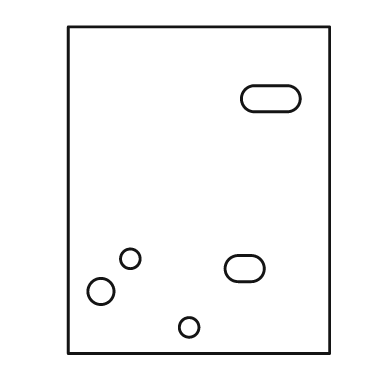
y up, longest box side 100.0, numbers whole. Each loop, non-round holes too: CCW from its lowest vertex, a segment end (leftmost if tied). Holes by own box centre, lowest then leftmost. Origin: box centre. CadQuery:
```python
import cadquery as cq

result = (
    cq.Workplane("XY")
    .moveTo(-40.0, -50.0)
    .lineTo(40.0, -50.0)
    .lineTo(40.0, 50.0)
    .lineTo(-40.0, 50.0)
    .close()
    .moveTo(-3.0, -42.0)
    .circle(3.0)
    .moveTo(-30.0, -31.0)
    .circle(4.0)
    .moveTo(12.0, -28.0)
    .lineTo(16.0, -28.0)
    .threePointArc((20.0, -24.0), (16.0, -20.0))
    .lineTo(12.0, -20.0)
    .threePointArc((8.0, -24.0), (12.0, -28.0))
    .close()
    .moveTo(-21.0, -21.0)
    .circle(3.0)
    .moveTo(17.0, 24.0)
    .lineTo(27.0, 24.0)
    .threePointArc((31.0, 28.0), (27.0, 32.0))
    .lineTo(17.0, 32.0)
    .threePointArc((13.0, 28.0), (17.0, 24.0))
    .close()
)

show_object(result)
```